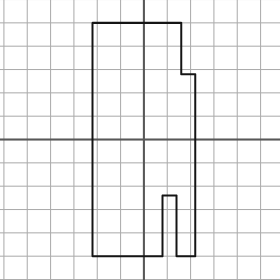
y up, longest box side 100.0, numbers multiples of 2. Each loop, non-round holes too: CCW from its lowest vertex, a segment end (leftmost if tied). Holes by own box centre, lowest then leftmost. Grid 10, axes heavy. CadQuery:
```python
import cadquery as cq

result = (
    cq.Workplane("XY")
    .moveTo(-22.0, -50.0)
    .lineTo(8.0, -50.0)
    .lineTo(8.0, -24.0)
    .lineTo(14.0, -24.0)
    .lineTo(14.0, -50.0)
    .lineTo(22.0, -50.0)
    .lineTo(22.0, 28.0)
    .lineTo(16.0, 28.0)
    .lineTo(16.0, 50.0)
    .lineTo(-22.0, 50.0)
    .close()
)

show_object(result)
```